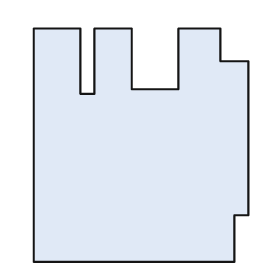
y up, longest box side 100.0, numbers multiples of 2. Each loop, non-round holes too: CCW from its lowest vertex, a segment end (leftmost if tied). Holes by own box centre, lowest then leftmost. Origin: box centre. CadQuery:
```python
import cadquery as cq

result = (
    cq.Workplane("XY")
    .moveTo(-46.0, -50.0)
    .lineTo(40.0, -50.0)
    .lineTo(40.0, -30.0)
    .lineTo(46.0, -30.0)
    .lineTo(46.0, 36.0)
    .lineTo(34.0, 36.0)
    .lineTo(34.0, 50.0)
    .lineTo(16.0, 50.0)
    .lineTo(16.0, 24.0)
    .lineTo(-4.0, 24.0)
    .lineTo(-4.0, 50.0)
    .lineTo(-20.0, 50.0)
    .lineTo(-20.0, 22.0)
    .lineTo(-26.0, 22.0)
    .lineTo(-26.0, 50.0)
    .lineTo(-46.0, 50.0)
    .close()
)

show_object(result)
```